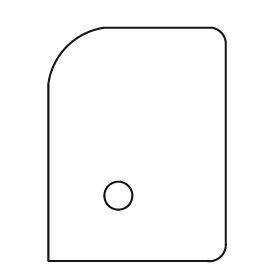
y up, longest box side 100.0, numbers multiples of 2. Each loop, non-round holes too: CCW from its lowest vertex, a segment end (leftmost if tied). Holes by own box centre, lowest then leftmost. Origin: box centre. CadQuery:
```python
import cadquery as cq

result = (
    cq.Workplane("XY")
    .moveTo(-38.0, -50.0)
    .lineTo(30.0, -50.0)
    .threePointArc((36.0, -48.0), (38.0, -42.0))
    .lineTo(38.0, 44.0)
    .threePointArc((36.0, 48.0), (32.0, 50.0))
    .lineTo(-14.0, 50.0)
    .threePointArc((-30.0, 42.0), (-38.0, 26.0))
    .close()
    .moveTo(-8.0, -22.0)
    .circle(6.0)
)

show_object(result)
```